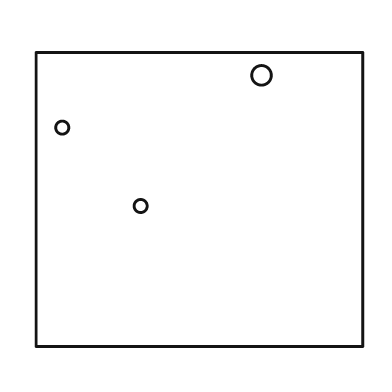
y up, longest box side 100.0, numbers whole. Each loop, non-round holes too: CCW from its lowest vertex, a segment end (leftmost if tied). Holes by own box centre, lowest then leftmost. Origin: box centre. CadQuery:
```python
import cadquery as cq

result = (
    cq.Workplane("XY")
    .moveTo(-50.0, -45.0)
    .lineTo(50.0, -45.0)
    .lineTo(50.0, 45.0)
    .lineTo(-50.0, 45.0)
    .close()
    .moveTo(-18.0, -2.0)
    .circle(2.0)
    .moveTo(-42.0, 22.0)
    .circle(2.0)
    .moveTo(19.0, 38.0)
    .circle(3.0)
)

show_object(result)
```